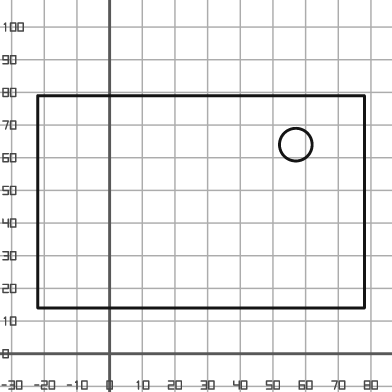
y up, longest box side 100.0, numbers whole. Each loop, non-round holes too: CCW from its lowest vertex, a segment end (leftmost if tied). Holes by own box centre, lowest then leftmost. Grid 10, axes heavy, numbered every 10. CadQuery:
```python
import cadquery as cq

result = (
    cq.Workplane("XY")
    .moveTo(-22.0, 14.0)
    .lineTo(78.0, 14.0)
    .lineTo(78.0, 79.0)
    .lineTo(-22.0, 79.0)
    .close()
    .moveTo(57.0, 64.0)
    .circle(5.0)
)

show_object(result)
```